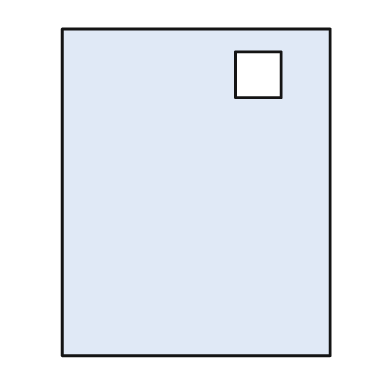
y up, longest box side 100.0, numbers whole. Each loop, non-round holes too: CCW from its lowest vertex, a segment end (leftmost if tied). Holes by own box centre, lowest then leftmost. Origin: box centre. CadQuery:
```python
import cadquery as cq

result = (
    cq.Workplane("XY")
    .moveTo(-41.0, -50.0)
    .lineTo(41.0, -50.0)
    .lineTo(41.0, 50.0)
    .lineTo(-41.0, 50.0)
    .close()
    .moveTo(12.0, 29.0)
    .lineTo(26.0, 29.0)
    .lineTo(26.0, 43.0)
    .lineTo(12.0, 43.0)
    .close()
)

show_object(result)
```